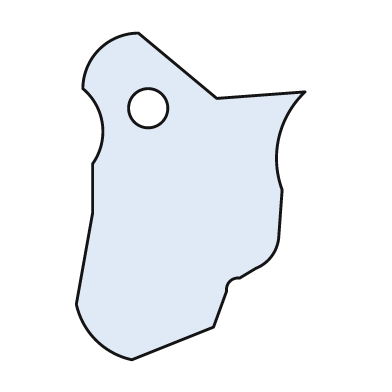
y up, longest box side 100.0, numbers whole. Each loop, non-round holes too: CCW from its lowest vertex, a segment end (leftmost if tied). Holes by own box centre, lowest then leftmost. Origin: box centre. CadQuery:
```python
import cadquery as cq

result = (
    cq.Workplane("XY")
    .moveTo(-18.0, -50.0)
    .lineTo(7.0, -40.0)
    .lineTo(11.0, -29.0)
    .threePointArc((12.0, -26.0), (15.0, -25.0))
    .lineTo(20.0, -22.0)
    .threePointArc((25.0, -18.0), (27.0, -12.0))
    .lineTo(28.0, 2.0)
    .threePointArc((27.0, 18.0), (35.0, 32.0))
    .lineTo(8.0, 30.0)
    .lineTo(-16.0, 50.0)
    .threePointArc((-28.0, 45.0), (-33.0, 33.0))
    .threePointArc((-27.0, 22.0), (-30.0, 10.0))
    .lineTo(-30.0, -5.0)
    .lineTo(-35.0, -33.0)
    .threePointArc((-29.0, -44.0), (-18.0, -50.0))
    .close()
    .moveTo(-13.0, 27.0)
    .circle(6.0)
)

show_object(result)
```